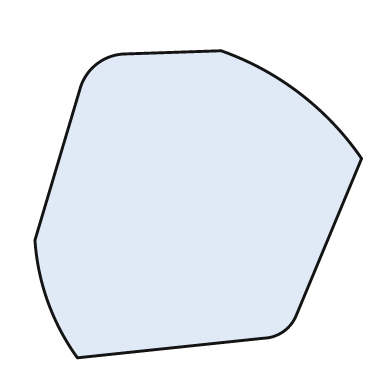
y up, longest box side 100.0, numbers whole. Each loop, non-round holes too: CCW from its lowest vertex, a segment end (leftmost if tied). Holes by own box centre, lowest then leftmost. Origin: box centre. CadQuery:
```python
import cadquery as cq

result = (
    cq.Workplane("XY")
    .moveTo(-37.0, -47.0)
    .lineTo(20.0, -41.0)
    .threePointArc((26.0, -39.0), (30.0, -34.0))
    .lineTo(50.0, 14.0)
    .threePointArc((31.0, 34.0), (7.0, 47.0))
    .lineTo(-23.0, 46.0)
    .threePointArc((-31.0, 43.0), (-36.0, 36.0))
    .lineTo(-50.0, -11.0)
    .threePointArc((-46.0, -30.0), (-37.0, -47.0))
    .close()
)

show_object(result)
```